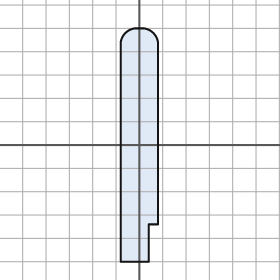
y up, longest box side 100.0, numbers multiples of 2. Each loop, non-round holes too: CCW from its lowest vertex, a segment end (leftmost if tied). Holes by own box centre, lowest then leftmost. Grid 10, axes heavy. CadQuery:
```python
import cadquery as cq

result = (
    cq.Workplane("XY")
    .moveTo(-8.0, -50.0)
    .lineTo(4.0, -50.0)
    .lineTo(4.0, -34.0)
    .lineTo(8.0, -34.0)
    .lineTo(8.0, 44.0)
    .threePointArc((6.0, 48.0), (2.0, 50.0))
    .lineTo(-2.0, 50.0)
    .threePointArc((-6.0, 48.0), (-8.0, 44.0))
    .close()
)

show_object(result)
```